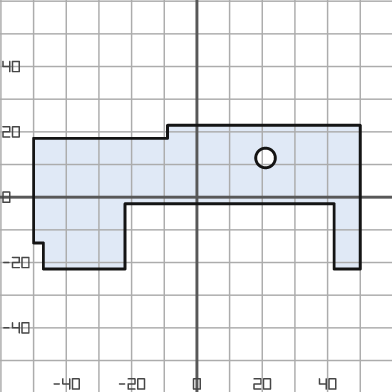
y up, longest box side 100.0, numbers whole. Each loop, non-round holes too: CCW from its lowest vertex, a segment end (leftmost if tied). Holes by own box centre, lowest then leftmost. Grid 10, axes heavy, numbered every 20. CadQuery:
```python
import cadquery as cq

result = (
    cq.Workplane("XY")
    .moveTo(-47.0, -22.0)
    .lineTo(-22.0, -22.0)
    .lineTo(-22.0, -2.0)
    .lineTo(42.0, -2.0)
    .lineTo(42.0, -22.0)
    .lineTo(50.0, -22.0)
    .lineTo(50.0, 22.0)
    .lineTo(-9.0, 22.0)
    .lineTo(-9.0, 18.0)
    .lineTo(-50.0, 18.0)
    .lineTo(-50.0, -14.0)
    .lineTo(-47.0, -14.0)
    .close()
    .moveTo(21.0, 12.0)
    .circle(3.0)
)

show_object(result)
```